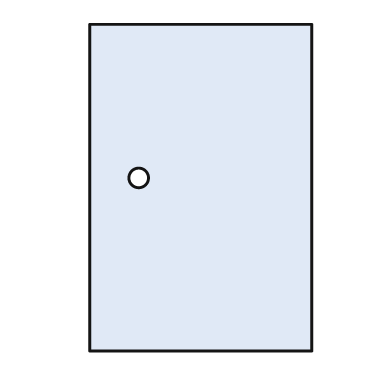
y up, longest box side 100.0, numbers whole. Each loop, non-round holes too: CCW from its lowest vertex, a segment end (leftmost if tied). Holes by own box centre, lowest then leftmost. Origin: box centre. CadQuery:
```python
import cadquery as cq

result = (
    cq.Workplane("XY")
    .moveTo(-34.0, -50.0)
    .lineTo(34.0, -50.0)
    .lineTo(34.0, 50.0)
    .lineTo(-34.0, 50.0)
    .close()
    .moveTo(-19.0, 3.0)
    .circle(3.0)
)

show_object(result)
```